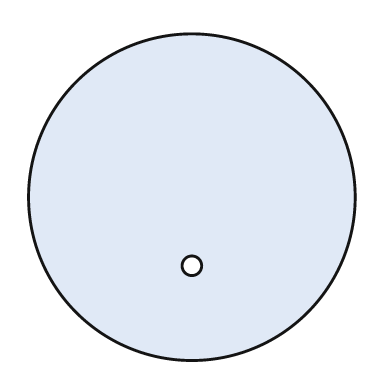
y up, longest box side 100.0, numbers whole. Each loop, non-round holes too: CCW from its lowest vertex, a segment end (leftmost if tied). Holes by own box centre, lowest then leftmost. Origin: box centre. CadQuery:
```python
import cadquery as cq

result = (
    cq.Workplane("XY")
    .moveTo(0.0, 0.0)
    .circle(50.0)
    .moveTo(0.0, -21.0)
    .circle(3.0)
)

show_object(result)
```